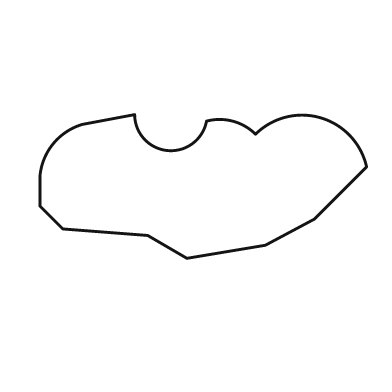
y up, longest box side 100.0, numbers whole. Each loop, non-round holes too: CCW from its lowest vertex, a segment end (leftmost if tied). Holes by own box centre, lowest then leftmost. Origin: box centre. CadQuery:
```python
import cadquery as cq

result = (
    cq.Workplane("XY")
    .moveTo(-5.0, -22.0)
    .lineTo(19.0, -18.0)
    .lineTo(34.0, -10.0)
    .lineTo(50.0, 6.0)
    .threePointArc((36.0, 21.0), (16.0, 16.0))
    .threePointArc((9.0, 20.0), (1.0, 20.0))
    .threePointArc((-11.0, 11.0), (-21.0, 22.0))
    .lineTo(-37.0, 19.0)
    .threePointArc((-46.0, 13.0), (-50.0, 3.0))
    .lineTo(-50.0, -6.0)
    .lineTo(-43.0, -13.0)
    .lineTo(-17.0, -15.0)
    .close()
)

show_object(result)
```